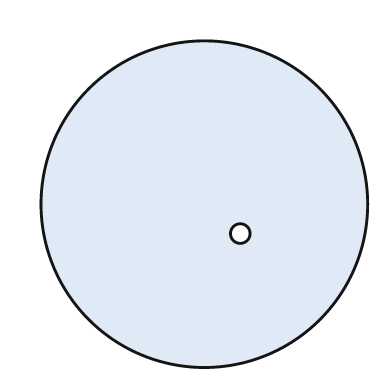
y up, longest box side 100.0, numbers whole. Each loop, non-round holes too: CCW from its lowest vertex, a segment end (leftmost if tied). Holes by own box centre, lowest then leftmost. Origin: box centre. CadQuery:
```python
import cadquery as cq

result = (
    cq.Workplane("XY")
    .moveTo(0.0, 0.0)
    .circle(50.0)
    .moveTo(11.0, -9.0)
    .circle(3.0)
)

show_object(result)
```